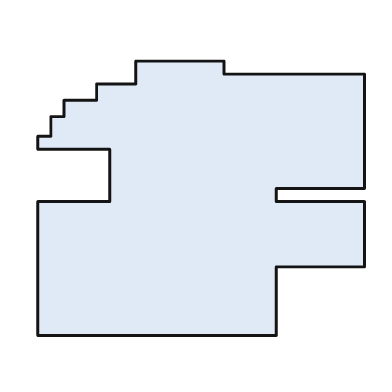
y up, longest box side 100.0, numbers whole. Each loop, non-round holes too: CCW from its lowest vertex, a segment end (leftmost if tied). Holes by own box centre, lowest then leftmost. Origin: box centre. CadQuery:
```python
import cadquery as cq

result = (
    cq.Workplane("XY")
    .moveTo(-50.0, -42.0)
    .lineTo(23.0, -42.0)
    .lineTo(23.0, -21.0)
    .lineTo(50.0, -21.0)
    .lineTo(50.0, -1.0)
    .lineTo(23.0, -1.0)
    .lineTo(23.0, 3.0)
    .lineTo(50.0, 3.0)
    .lineTo(50.0, 38.0)
    .lineTo(7.0, 38.0)
    .lineTo(7.0, 42.0)
    .lineTo(-20.0, 42.0)
    .lineTo(-20.0, 35.0)
    .lineTo(-32.0, 35.0)
    .lineTo(-32.0, 30.0)
    .lineTo(-42.0, 30.0)
    .lineTo(-42.0, 25.0)
    .lineTo(-46.0, 25.0)
    .lineTo(-46.0, 19.0)
    .lineTo(-50.0, 19.0)
    .lineTo(-50.0, 15.0)
    .lineTo(-28.0, 15.0)
    .lineTo(-28.0, -1.0)
    .lineTo(-50.0, -1.0)
    .close()
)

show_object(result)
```